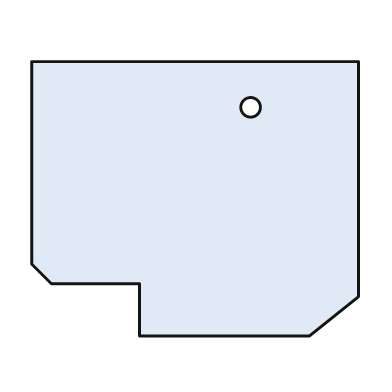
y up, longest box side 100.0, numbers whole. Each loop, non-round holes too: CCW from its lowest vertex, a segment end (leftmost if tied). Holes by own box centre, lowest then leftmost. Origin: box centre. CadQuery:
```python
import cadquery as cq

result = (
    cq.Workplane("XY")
    .moveTo(-17.0, -42.0)
    .lineTo(35.0, -42.0)
    .lineTo(50.0, -30.0)
    .lineTo(50.0, 42.0)
    .lineTo(-50.0, 42.0)
    .lineTo(-50.0, -20.0)
    .lineTo(-44.0, -26.0)
    .lineTo(-17.0, -26.0)
    .close()
    .moveTo(17.0, 28.0)
    .circle(3.0)
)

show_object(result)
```